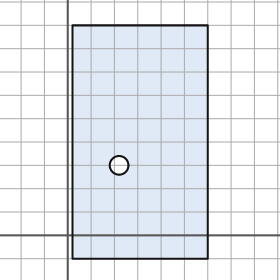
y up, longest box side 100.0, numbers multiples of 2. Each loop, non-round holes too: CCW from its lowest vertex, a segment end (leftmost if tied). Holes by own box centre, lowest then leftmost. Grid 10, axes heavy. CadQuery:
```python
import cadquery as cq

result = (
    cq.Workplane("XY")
    .moveTo(2.0, -10.0)
    .lineTo(60.0, -10.0)
    .lineTo(60.0, 90.0)
    .lineTo(2.0, 90.0)
    .close()
    .moveTo(22.0, 30.0)
    .circle(4.0)
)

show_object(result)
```